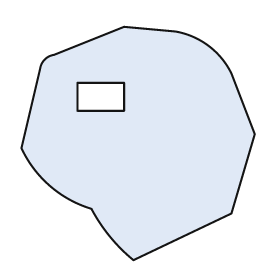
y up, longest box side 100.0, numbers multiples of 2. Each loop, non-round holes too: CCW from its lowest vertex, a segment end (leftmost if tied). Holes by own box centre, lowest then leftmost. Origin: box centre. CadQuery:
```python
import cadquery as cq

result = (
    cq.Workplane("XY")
    .moveTo(-2.0, -50.0)
    .lineTo(40.0, -30.0)
    .lineTo(50.0, 4.0)
    .lineTo(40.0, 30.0)
    .threePointArc((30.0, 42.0), (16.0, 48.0))
    .lineTo(-6.0, 50.0)
    .lineTo(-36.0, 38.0)
    .threePointArc((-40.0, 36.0), (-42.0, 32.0))
    .lineTo(-50.0, -2.0)
    .threePointArc((-38.0, -18.0), (-20.0, -28.0))
    .threePointArc((-12.0, -40.0), (-2.0, -50.0))
    .close()
    .moveTo(-26.0, 14.0)
    .lineTo(-6.0, 14.0)
    .lineTo(-6.0, 26.0)
    .lineTo(-26.0, 26.0)
    .close()
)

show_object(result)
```